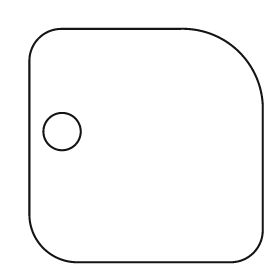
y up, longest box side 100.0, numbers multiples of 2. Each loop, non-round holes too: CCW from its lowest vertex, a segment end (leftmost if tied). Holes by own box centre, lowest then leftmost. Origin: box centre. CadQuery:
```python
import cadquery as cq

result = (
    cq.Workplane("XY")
    .moveTo(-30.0, -50.0)
    .lineTo(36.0, -50.0)
    .threePointArc((46.0, -46.0), (50.0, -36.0))
    .lineTo(50.0, 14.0)
    .threePointArc((40.0, 40.0), (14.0, 50.0))
    .lineTo(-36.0, 50.0)
    .threePointArc((-46.0, 46.0), (-50.0, 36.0))
    .lineTo(-50.0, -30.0)
    .threePointArc((-44.0, -44.0), (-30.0, -50.0))
    .close()
    .moveTo(-36.0, 6.0)
    .circle(8.0)
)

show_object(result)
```